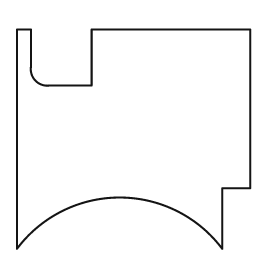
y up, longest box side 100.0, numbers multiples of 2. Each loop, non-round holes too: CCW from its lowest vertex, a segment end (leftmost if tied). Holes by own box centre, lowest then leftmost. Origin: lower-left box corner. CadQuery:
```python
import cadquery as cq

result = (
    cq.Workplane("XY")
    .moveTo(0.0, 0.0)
    .threePointArc((44.0, 22.0), (88.0, 0.0))
    .lineTo(88.0, 26.0)
    .lineTo(100.0, 26.0)
    .lineTo(100.0, 94.0)
    .lineTo(32.0, 94.0)
    .lineTo(32.0, 70.0)
    .lineTo(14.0, 70.0)
    .threePointArc((8.0, 72.0), (6.0, 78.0))
    .lineTo(6.0, 94.0)
    .lineTo(0.0, 94.0)
    .close()
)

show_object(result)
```